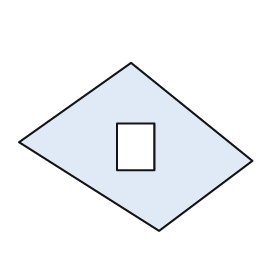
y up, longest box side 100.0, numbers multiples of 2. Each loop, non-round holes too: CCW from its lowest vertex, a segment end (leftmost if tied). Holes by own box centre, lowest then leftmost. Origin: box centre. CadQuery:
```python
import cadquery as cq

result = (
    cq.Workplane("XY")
    .moveTo(10.0, -36.0)
    .lineTo(50.0, -6.0)
    .lineTo(-2.0, 36.0)
    .lineTo(-50.0, 2.0)
    .close()
    .moveTo(-8.0, -10.0)
    .lineTo(8.0, -10.0)
    .lineTo(8.0, 10.0)
    .lineTo(-8.0, 10.0)
    .close()
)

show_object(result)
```